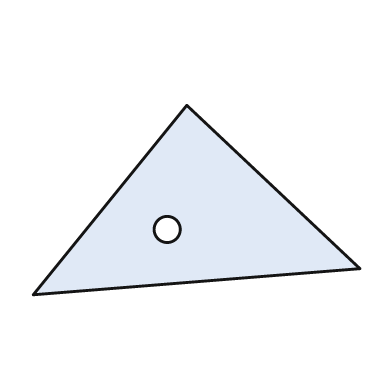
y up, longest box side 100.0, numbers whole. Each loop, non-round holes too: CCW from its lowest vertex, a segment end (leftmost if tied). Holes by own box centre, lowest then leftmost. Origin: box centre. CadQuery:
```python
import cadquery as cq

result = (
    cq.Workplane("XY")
    .moveTo(-50.0, -29.0)
    .lineTo(50.0, -21.0)
    .lineTo(-3.0, 29.0)
    .close()
    .moveTo(-9.0, -9.0)
    .circle(4.0)
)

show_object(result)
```